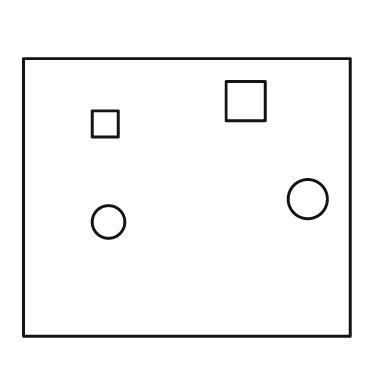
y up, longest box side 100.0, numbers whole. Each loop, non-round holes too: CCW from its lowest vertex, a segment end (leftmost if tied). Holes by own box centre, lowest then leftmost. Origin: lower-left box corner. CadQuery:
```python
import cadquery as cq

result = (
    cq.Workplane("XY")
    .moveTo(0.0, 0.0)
    .lineTo(100.0, 0.0)
    .lineTo(100.0, 85.0)
    .lineTo(0.0, 85.0)
    .close()
    .moveTo(26.0, 35.0)
    .circle(5.0)
    .moveTo(87.0, 42.0)
    .circle(6.0)
    .moveTo(21.0, 61.0)
    .lineTo(29.0, 61.0)
    .lineTo(29.0, 69.0)
    .lineTo(21.0, 69.0)
    .close()
    .moveTo(62.0, 66.0)
    .lineTo(74.0, 66.0)
    .lineTo(74.0, 78.0)
    .lineTo(62.0, 78.0)
    .close()
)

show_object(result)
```